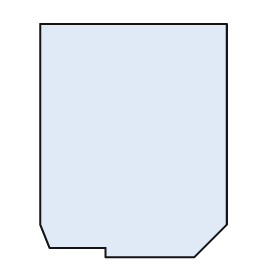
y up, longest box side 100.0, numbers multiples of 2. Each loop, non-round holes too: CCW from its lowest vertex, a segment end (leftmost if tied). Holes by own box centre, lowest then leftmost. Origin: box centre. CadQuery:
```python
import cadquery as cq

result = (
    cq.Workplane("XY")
    .moveTo(-12.0, -50.0)
    .lineTo(26.0, -50.0)
    .lineTo(40.0, -36.0)
    .lineTo(40.0, 50.0)
    .lineTo(-40.0, 50.0)
    .lineTo(-40.0, -36.0)
    .lineTo(-36.0, -46.0)
    .lineTo(-12.0, -46.0)
    .close()
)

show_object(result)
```